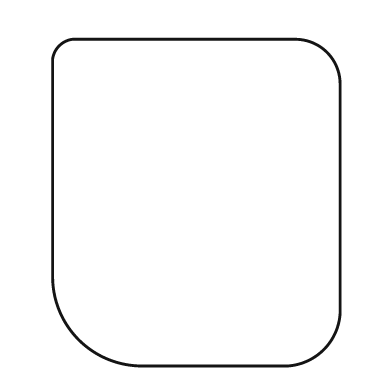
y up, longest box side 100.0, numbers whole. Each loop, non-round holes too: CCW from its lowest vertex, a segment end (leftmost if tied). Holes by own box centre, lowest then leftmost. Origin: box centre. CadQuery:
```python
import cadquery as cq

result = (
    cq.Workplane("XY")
    .moveTo(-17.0, -50.0)
    .lineTo(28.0, -50.0)
    .threePointArc((39.0, -45.0), (44.0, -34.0))
    .lineTo(44.0, 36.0)
    .threePointArc((40.0, 46.0), (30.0, 50.0))
    .lineTo(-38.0, 50.0)
    .threePointArc((-42.0, 48.0), (-44.0, 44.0))
    .lineTo(-44.0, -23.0)
    .threePointArc((-36.0, -42.0), (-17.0, -50.0))
    .close()
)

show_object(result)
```